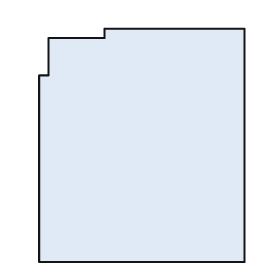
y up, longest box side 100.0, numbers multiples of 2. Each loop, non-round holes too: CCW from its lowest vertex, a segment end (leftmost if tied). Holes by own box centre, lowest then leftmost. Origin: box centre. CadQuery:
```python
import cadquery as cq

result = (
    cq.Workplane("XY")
    .moveTo(-44.0, -50.0)
    .lineTo(44.0, -50.0)
    .lineTo(44.0, 50.0)
    .lineTo(-16.0, 50.0)
    .lineTo(-16.0, 46.0)
    .lineTo(-40.0, 46.0)
    .lineTo(-40.0, 30.0)
    .lineTo(-44.0, 30.0)
    .close()
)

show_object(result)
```